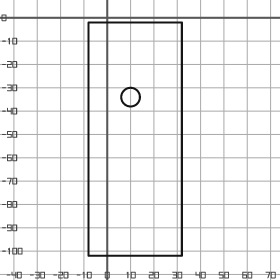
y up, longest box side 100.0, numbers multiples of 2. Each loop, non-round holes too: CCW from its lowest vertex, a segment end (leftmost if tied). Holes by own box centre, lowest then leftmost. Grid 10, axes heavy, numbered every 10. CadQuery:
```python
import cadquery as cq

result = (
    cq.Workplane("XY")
    .moveTo(-8.0, -102.0)
    .lineTo(32.0, -102.0)
    .lineTo(32.0, -2.0)
    .lineTo(-8.0, -2.0)
    .close()
    .moveTo(10.0, -34.0)
    .circle(4.0)
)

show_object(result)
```